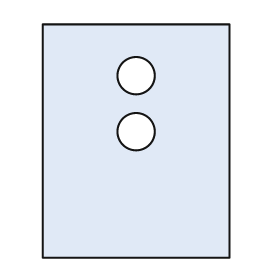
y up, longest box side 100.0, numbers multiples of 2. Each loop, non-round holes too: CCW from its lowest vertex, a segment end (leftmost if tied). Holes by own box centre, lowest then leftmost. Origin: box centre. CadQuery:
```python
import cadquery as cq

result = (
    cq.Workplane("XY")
    .moveTo(-40.0, -50.0)
    .lineTo(40.0, -50.0)
    .lineTo(40.0, 50.0)
    .lineTo(-40.0, 50.0)
    .close()
    .moveTo(0.0, 4.0)
    .circle(8.0)
    .moveTo(0.0, 28.0)
    .circle(8.0)
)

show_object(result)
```